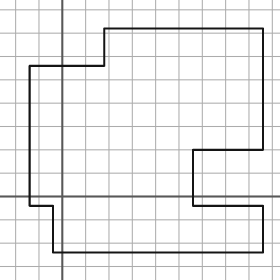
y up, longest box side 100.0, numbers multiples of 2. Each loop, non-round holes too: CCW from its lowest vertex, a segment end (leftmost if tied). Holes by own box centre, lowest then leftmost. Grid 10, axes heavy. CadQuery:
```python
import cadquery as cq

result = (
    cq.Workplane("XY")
    .moveTo(-4.0, -24.0)
    .lineTo(86.0, -24.0)
    .lineTo(86.0, -4.0)
    .lineTo(56.0, -4.0)
    .lineTo(56.0, 20.0)
    .lineTo(86.0, 20.0)
    .lineTo(86.0, 72.0)
    .lineTo(18.0, 72.0)
    .lineTo(18.0, 56.0)
    .lineTo(-14.0, 56.0)
    .lineTo(-14.0, -4.0)
    .lineTo(-4.0, -4.0)
    .close()
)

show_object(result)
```